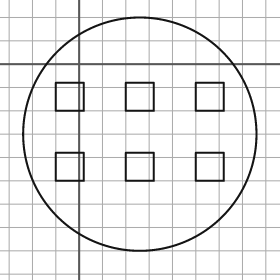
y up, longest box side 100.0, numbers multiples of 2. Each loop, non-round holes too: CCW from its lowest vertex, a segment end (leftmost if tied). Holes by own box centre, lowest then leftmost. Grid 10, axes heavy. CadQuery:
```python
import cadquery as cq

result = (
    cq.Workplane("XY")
    .moveTo(26.0, -30.0)
    .circle(50.0)
    .moveTo(-10.0, -50.0)
    .lineTo(2.0, -50.0)
    .lineTo(2.0, -38.0)
    .lineTo(-10.0, -38.0)
    .close()
    .moveTo(20.0, -50.0)
    .lineTo(32.0, -50.0)
    .lineTo(32.0, -38.0)
    .lineTo(20.0, -38.0)
    .close()
    .moveTo(50.0, -50.0)
    .lineTo(62.0, -50.0)
    .lineTo(62.0, -38.0)
    .lineTo(50.0, -38.0)
    .close()
    .moveTo(-10.0, -20.0)
    .lineTo(2.0, -20.0)
    .lineTo(2.0, -8.0)
    .lineTo(-10.0, -8.0)
    .close()
    .moveTo(20.0, -20.0)
    .lineTo(32.0, -20.0)
    .lineTo(32.0, -8.0)
    .lineTo(20.0, -8.0)
    .close()
    .moveTo(50.0, -20.0)
    .lineTo(62.0, -20.0)
    .lineTo(62.0, -8.0)
    .lineTo(50.0, -8.0)
    .close()
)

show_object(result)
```